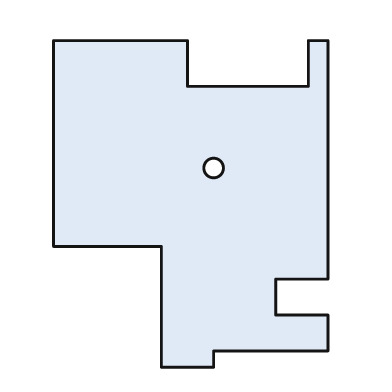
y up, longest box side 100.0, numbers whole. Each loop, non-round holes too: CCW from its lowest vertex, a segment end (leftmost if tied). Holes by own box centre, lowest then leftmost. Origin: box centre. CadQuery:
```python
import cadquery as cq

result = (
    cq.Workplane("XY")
    .moveTo(-9.0, -50.0)
    .lineTo(7.0, -50.0)
    .lineTo(7.0, -45.0)
    .lineTo(42.0, -45.0)
    .lineTo(42.0, -34.0)
    .lineTo(26.0, -34.0)
    .lineTo(26.0, -23.0)
    .lineTo(42.0, -23.0)
    .lineTo(42.0, 50.0)
    .lineTo(36.0, 50.0)
    .lineTo(36.0, 36.0)
    .lineTo(-1.0, 36.0)
    .lineTo(-1.0, 50.0)
    .lineTo(-42.0, 50.0)
    .lineTo(-42.0, -13.0)
    .lineTo(-9.0, -13.0)
    .close()
    .moveTo(7.0, 11.0)
    .circle(3.0)
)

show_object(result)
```